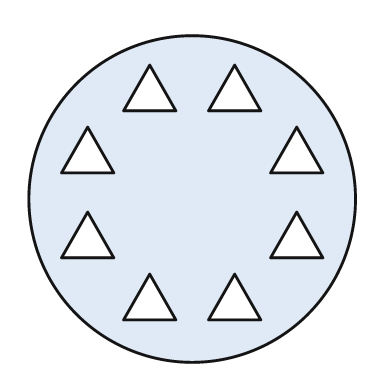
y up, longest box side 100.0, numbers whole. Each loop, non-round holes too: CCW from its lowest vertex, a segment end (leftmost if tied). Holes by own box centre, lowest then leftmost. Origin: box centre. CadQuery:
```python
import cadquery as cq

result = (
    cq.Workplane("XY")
    .moveTo(0.0, 0.0)
    .circle(50.0)
    .moveTo(-21.0, -37.0)
    .lineTo(-5.0, -37.0)
    .lineTo(-13.0, -23.0)
    .close()
    .moveTo(5.0, -37.0)
    .lineTo(21.0, -37.0)
    .lineTo(13.0, -23.0)
    .close()
    .moveTo(-40.0, -18.0)
    .lineTo(-24.0, -18.0)
    .lineTo(-32.0, -4.0)
    .close()
    .moveTo(24.0, -18.0)
    .lineTo(40.0, -18.0)
    .lineTo(32.0, -4.0)
    .close()
    .moveTo(-40.0, 8.0)
    .lineTo(-24.0, 8.0)
    .lineTo(-32.0, 22.0)
    .close()
    .moveTo(24.0, 8.0)
    .lineTo(40.0, 8.0)
    .lineTo(32.0, 22.0)
    .close()
    .moveTo(-21.0, 27.0)
    .lineTo(-5.0, 27.0)
    .lineTo(-13.0, 41.0)
    .close()
    .moveTo(5.0, 27.0)
    .lineTo(21.0, 27.0)
    .lineTo(13.0, 41.0)
    .close()
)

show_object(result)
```